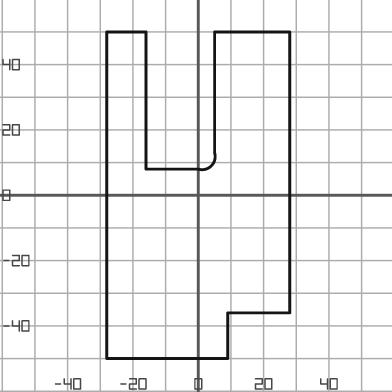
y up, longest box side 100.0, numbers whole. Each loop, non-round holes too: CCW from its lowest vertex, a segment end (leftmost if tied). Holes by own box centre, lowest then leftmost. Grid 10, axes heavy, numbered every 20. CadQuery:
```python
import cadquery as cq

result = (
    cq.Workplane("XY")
    .moveTo(-28.0, -50.0)
    .lineTo(9.0, -50.0)
    .lineTo(9.0, -36.0)
    .lineTo(28.0, -36.0)
    .lineTo(28.0, 50.0)
    .lineTo(5.0, 50.0)
    .lineTo(5.0, 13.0)
    .threePointArc((4.0, 9.0), (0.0, 8.0))
    .lineTo(-16.0, 8.0)
    .lineTo(-16.0, 50.0)
    .lineTo(-28.0, 50.0)
    .close()
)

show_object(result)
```